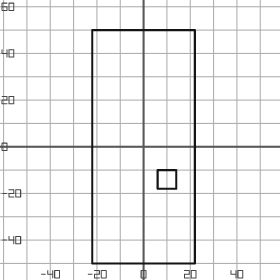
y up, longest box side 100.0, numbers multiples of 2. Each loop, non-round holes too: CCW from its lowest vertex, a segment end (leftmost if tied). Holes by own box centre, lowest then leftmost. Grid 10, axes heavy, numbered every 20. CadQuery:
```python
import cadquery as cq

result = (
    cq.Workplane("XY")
    .moveTo(-22.0, -50.0)
    .lineTo(22.0, -50.0)
    .lineTo(22.0, 50.0)
    .lineTo(-22.0, 50.0)
    .close()
    .moveTo(6.0, -18.0)
    .lineTo(14.0, -18.0)
    .lineTo(14.0, -10.0)
    .lineTo(6.0, -10.0)
    .close()
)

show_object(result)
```